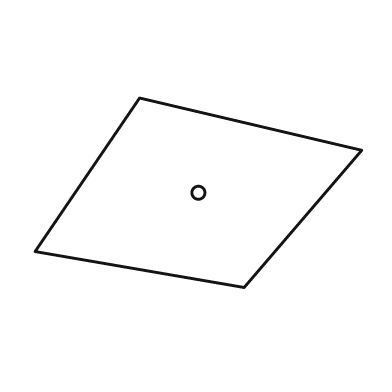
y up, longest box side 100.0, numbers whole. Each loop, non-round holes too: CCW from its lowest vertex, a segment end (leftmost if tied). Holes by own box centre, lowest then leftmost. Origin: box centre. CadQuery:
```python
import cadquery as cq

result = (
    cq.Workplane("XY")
    .moveTo(14.0, -29.0)
    .lineTo(50.0, 13.0)
    .lineTo(-18.0, 29.0)
    .lineTo(-50.0, -18.0)
    .close()
    .moveTo(0.0, 0.0)
    .circle(2.0)
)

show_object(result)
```